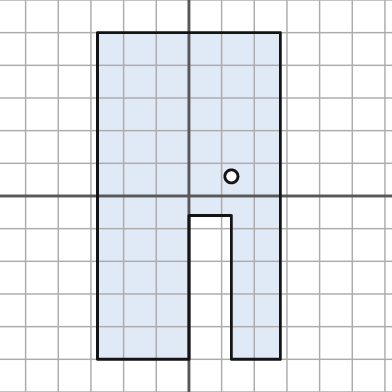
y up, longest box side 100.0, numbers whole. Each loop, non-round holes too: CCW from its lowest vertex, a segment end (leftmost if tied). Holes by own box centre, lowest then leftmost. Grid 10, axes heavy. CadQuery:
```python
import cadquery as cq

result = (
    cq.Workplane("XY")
    .moveTo(-28.0, -50.0)
    .lineTo(0.0, -50.0)
    .lineTo(0.0, -6.0)
    .lineTo(13.0, -6.0)
    .lineTo(13.0, -50.0)
    .lineTo(28.0, -50.0)
    .lineTo(28.0, 50.0)
    .lineTo(-28.0, 50.0)
    .close()
    .moveTo(13.0, 6.0)
    .circle(2.0)
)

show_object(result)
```